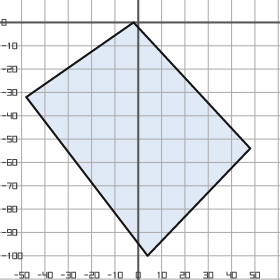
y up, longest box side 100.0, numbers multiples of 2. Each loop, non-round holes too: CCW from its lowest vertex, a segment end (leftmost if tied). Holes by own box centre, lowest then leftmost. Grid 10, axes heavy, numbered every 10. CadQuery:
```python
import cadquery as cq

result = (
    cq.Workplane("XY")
    .moveTo(4.0, -100.0)
    .lineTo(48.0, -54.0)
    .lineTo(-2.0, 0.0)
    .lineTo(-48.0, -32.0)
    .close()
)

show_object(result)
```